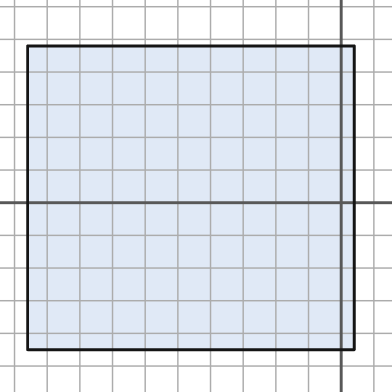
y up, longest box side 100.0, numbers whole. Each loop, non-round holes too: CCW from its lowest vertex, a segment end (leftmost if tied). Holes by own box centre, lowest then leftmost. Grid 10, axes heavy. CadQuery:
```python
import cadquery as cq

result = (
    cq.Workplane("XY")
    .moveTo(-96.0, -45.0)
    .lineTo(4.0, -45.0)
    .lineTo(4.0, 48.0)
    .lineTo(-96.0, 48.0)
    .close()
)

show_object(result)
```